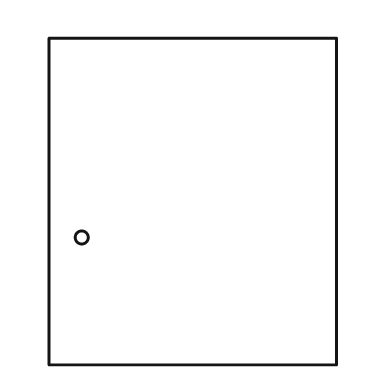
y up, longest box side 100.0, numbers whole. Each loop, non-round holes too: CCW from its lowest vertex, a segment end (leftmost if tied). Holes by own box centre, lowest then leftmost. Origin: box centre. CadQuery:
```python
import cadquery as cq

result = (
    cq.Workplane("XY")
    .moveTo(-44.0, -50.0)
    .lineTo(44.0, -50.0)
    .lineTo(44.0, 50.0)
    .lineTo(-44.0, 50.0)
    .close()
    .moveTo(-34.0, -11.0)
    .circle(2.0)
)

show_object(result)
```